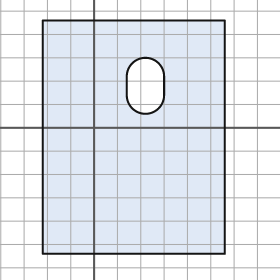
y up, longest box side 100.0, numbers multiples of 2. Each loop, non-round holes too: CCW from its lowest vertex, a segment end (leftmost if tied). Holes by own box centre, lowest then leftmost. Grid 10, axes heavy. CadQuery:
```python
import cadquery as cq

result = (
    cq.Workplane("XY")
    .moveTo(-22.0, -54.0)
    .lineTo(56.0, -54.0)
    .lineTo(56.0, 46.0)
    .lineTo(-22.0, 46.0)
    .close()
    .moveTo(14.0, 14.0)
    .threePointArc((22.0, 6.0), (30.0, 14.0))
    .lineTo(30.0, 22.0)
    .threePointArc((22.0, 30.0), (14.0, 22.0))
    .close()
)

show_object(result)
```